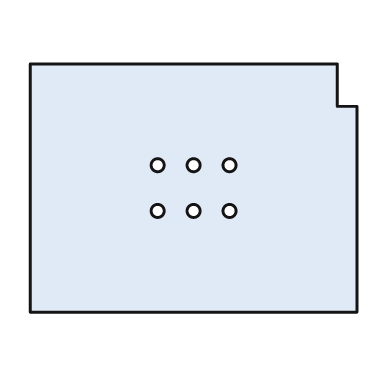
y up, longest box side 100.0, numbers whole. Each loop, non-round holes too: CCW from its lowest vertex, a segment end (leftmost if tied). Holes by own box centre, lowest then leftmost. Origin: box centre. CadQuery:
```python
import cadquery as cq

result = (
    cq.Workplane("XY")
    .moveTo(-50.0, -38.0)
    .lineTo(50.0, -38.0)
    .lineTo(50.0, 25.0)
    .lineTo(44.0, 25.0)
    .lineTo(44.0, 38.0)
    .lineTo(-50.0, 38.0)
    .close()
    .moveTo(-11.0, -7.0)
    .circle(2.0)
    .moveTo(0.0, -7.0)
    .circle(2.0)
    .moveTo(11.0, -7.0)
    .circle(2.0)
    .moveTo(-11.0, 7.0)
    .circle(2.0)
    .moveTo(0.0, 7.0)
    .circle(2.0)
    .moveTo(11.0, 7.0)
    .circle(2.0)
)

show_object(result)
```